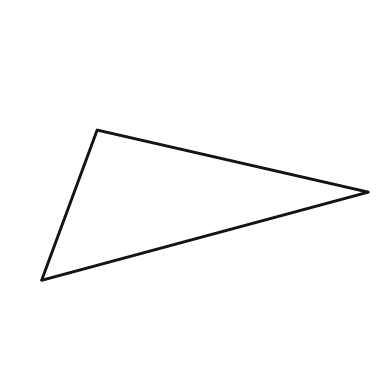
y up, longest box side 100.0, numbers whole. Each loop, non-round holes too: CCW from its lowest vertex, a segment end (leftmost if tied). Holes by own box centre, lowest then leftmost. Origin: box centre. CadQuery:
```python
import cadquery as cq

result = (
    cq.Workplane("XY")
    .moveTo(-50.0, -23.0)
    .lineTo(50.0, 4.0)
    .lineTo(-33.0, 23.0)
    .close()
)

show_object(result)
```